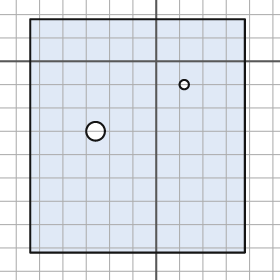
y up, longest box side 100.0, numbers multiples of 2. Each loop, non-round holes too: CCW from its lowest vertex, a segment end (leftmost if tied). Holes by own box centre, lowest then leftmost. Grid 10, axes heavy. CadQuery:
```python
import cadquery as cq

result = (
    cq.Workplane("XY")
    .moveTo(-54.0, -82.0)
    .lineTo(38.0, -82.0)
    .lineTo(38.0, 18.0)
    .lineTo(-54.0, 18.0)
    .close()
    .moveTo(-26.0, -30.0)
    .circle(4.0)
    .moveTo(12.0, -10.0)
    .circle(2.0)
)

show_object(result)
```